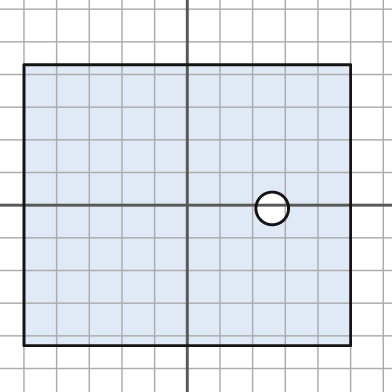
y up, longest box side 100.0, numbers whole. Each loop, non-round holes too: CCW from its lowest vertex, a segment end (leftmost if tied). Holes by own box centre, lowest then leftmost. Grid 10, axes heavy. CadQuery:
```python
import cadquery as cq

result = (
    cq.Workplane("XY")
    .moveTo(-50.0, -43.0)
    .lineTo(50.0, -43.0)
    .lineTo(50.0, 43.0)
    .lineTo(-50.0, 43.0)
    .close()
    .moveTo(26.0, -1.0)
    .circle(5.0)
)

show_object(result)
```